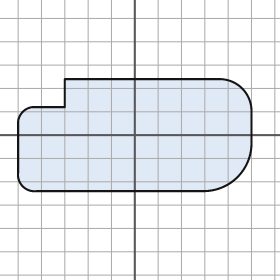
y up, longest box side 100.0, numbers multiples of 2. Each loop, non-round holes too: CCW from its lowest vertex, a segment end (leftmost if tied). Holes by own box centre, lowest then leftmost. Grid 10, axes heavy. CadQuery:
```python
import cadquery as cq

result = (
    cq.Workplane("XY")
    .moveTo(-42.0, -24.0)
    .lineTo(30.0, -24.0)
    .threePointArc((44.0, -18.0), (50.0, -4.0))
    .lineTo(50.0, 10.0)
    .threePointArc((46.0, 20.0), (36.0, 24.0))
    .lineTo(-30.0, 24.0)
    .lineTo(-30.0, 12.0)
    .lineTo(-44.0, 12.0)
    .threePointArc((-48.0, 10.0), (-50.0, 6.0))
    .lineTo(-50.0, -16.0)
    .threePointArc((-48.0, -22.0), (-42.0, -24.0))
    .close()
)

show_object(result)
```